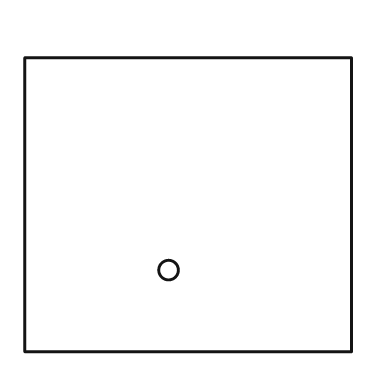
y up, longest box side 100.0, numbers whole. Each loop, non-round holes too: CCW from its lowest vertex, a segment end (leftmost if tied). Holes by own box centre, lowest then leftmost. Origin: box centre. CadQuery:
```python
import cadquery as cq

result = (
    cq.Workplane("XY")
    .moveTo(-50.0, -45.0)
    .lineTo(50.0, -45.0)
    .lineTo(50.0, 45.0)
    .lineTo(-50.0, 45.0)
    .close()
    .moveTo(-6.0, -20.0)
    .circle(3.0)
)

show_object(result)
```